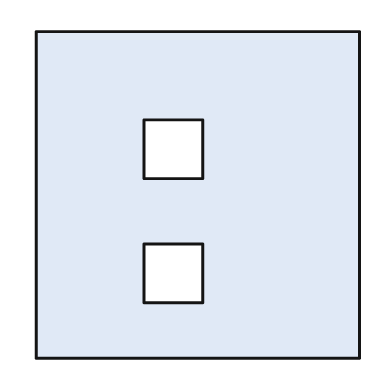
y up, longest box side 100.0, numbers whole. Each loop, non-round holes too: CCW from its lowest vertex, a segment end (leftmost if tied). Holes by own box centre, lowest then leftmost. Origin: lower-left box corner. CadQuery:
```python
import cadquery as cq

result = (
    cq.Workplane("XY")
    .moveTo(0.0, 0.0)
    .lineTo(99.0, 0.0)
    .lineTo(99.0, 100.0)
    .lineTo(0.0, 100.0)
    .close()
    .moveTo(33.0, 17.0)
    .lineTo(51.0, 17.0)
    .lineTo(51.0, 35.0)
    .lineTo(33.0, 35.0)
    .close()
    .moveTo(33.0, 55.0)
    .lineTo(51.0, 55.0)
    .lineTo(51.0, 73.0)
    .lineTo(33.0, 73.0)
    .close()
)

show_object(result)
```